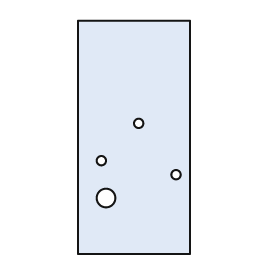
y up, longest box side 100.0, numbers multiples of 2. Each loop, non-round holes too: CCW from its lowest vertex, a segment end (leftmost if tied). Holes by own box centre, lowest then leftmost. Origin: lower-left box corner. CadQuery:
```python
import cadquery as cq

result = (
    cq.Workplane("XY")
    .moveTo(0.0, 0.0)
    .lineTo(48.0, 0.0)
    .lineTo(48.0, 100.0)
    .lineTo(0.0, 100.0)
    .close()
    .moveTo(12.0, 24.0)
    .circle(4.0)
    .moveTo(42.0, 34.0)
    .circle(2.0)
    .moveTo(10.0, 40.0)
    .circle(2.0)
    .moveTo(26.0, 56.0)
    .circle(2.0)
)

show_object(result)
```